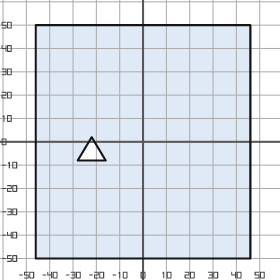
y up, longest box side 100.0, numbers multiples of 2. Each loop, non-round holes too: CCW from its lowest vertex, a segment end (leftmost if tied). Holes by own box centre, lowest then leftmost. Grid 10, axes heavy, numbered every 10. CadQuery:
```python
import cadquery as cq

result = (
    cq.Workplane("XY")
    .moveTo(-46.0, -50.0)
    .lineTo(46.0, -50.0)
    .lineTo(46.0, 50.0)
    .lineTo(-46.0, 50.0)
    .close()
    .moveTo(-28.0, -8.0)
    .lineTo(-16.0, -8.0)
    .lineTo(-22.0, 2.0)
    .close()
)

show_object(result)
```